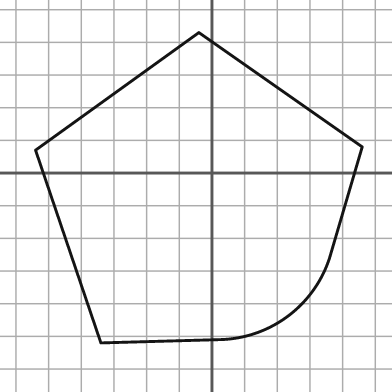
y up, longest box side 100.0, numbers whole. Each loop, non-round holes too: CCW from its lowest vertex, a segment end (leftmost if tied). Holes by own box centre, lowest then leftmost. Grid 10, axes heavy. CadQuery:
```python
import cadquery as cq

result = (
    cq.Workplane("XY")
    .moveTo(-34.0, -52.0)
    .lineTo(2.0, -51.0)
    .threePointArc((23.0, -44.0), (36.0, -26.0))
    .lineTo(46.0, 8.0)
    .lineTo(-4.0, 43.0)
    .lineTo(-54.0, 7.0)
    .close()
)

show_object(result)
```